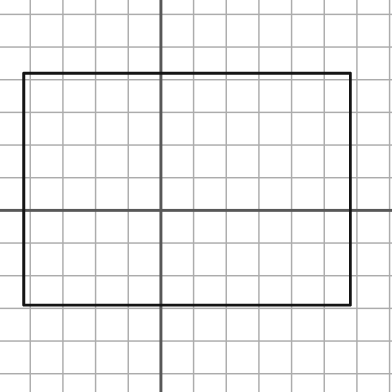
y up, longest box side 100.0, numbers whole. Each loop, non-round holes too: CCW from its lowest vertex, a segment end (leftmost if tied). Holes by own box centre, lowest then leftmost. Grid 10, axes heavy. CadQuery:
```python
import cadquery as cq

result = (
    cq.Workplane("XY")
    .moveTo(-42.0, -29.0)
    .lineTo(58.0, -29.0)
    .lineTo(58.0, 42.0)
    .lineTo(-42.0, 42.0)
    .close()
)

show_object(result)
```